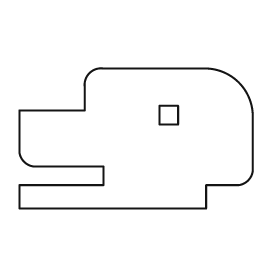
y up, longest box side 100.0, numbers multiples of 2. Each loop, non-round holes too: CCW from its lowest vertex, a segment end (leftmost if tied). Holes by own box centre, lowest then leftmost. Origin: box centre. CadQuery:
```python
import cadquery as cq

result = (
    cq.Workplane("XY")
    .moveTo(-50.0, -30.0)
    .lineTo(30.0, -30.0)
    .lineTo(30.0, -20.0)
    .lineTo(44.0, -20.0)
    .threePointArc((48.0, -18.0), (50.0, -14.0))
    .lineTo(50.0, 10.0)
    .threePointArc((44.0, 24.0), (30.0, 30.0))
    .lineTo(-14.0, 30.0)
    .threePointArc((-20.0, 28.0), (-22.0, 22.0))
    .lineTo(-22.0, 12.0)
    .lineTo(-50.0, 12.0)
    .lineTo(-50.0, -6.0)
    .threePointArc((-48.0, -10.0), (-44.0, -12.0))
    .lineTo(-14.0, -12.0)
    .lineTo(-14.0, -20.0)
    .lineTo(-50.0, -20.0)
    .close()
    .moveTo(10.0, 6.0)
    .lineTo(18.0, 6.0)
    .lineTo(18.0, 14.0)
    .lineTo(10.0, 14.0)
    .close()
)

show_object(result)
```